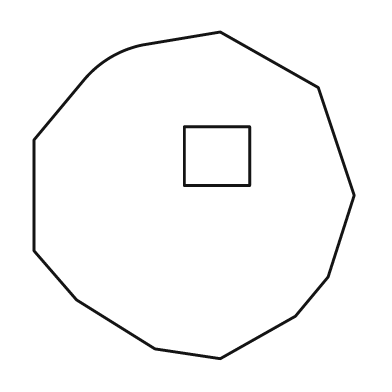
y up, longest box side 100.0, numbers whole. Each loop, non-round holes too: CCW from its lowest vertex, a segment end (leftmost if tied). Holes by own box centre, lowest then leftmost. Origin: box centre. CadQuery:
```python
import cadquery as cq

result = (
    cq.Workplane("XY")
    .moveTo(8.0, -50.0)
    .lineTo(31.0, -37.0)
    .lineTo(41.0, -25.0)
    .lineTo(49.0, 0.0)
    .lineTo(38.0, 33.0)
    .lineTo(8.0, 50.0)
    .lineTo(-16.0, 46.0)
    .threePointArc((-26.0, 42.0), (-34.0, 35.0))
    .lineTo(-49.0, 17.0)
    .lineTo(-49.0, -17.0)
    .lineTo(-36.0, -32.0)
    .lineTo(-12.0, -47.0)
    .close()
    .moveTo(-3.0, 3.0)
    .lineTo(17.0, 3.0)
    .lineTo(17.0, 21.0)
    .lineTo(-3.0, 21.0)
    .close()
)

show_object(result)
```